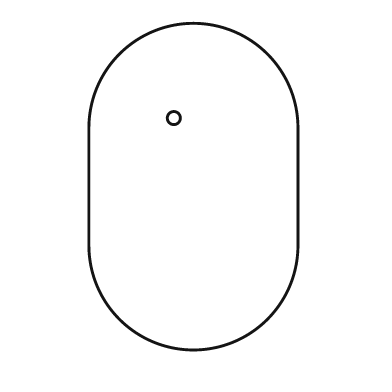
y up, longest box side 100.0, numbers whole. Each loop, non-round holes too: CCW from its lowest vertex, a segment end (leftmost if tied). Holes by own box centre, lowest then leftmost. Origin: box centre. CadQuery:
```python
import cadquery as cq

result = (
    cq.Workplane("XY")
    .moveTo(-32.0, -18.0)
    .threePointArc((0.0, -50.0), (32.0, -18.0))
    .lineTo(32.0, 18.0)
    .threePointArc((0.0, 50.0), (-32.0, 18.0))
    .close()
    .moveTo(-6.0, 21.0)
    .circle(2.0)
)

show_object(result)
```